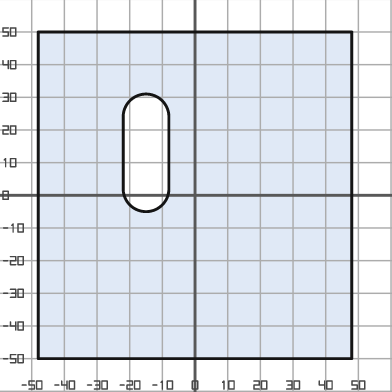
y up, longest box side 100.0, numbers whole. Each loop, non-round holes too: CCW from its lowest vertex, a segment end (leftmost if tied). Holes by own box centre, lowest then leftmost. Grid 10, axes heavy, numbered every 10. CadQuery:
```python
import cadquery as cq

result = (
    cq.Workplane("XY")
    .moveTo(-48.0, -50.0)
    .lineTo(48.0, -50.0)
    .lineTo(48.0, 50.0)
    .lineTo(-48.0, 50.0)
    .close()
    .moveTo(-22.0, 2.0)
    .threePointArc((-15.0, -5.0), (-8.0, 2.0))
    .lineTo(-8.0, 24.0)
    .threePointArc((-15.0, 31.0), (-22.0, 24.0))
    .close()
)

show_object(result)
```